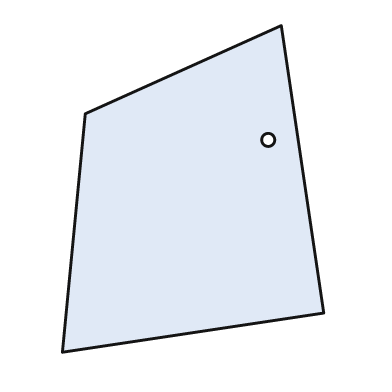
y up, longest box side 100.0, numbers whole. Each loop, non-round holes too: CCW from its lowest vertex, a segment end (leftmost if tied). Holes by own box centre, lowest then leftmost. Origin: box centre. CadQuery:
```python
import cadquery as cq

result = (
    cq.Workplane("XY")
    .moveTo(-40.0, -50.0)
    .lineTo(40.0, -38.0)
    .lineTo(27.0, 50.0)
    .lineTo(-33.0, 23.0)
    .close()
    .moveTo(23.0, 15.0)
    .circle(2.0)
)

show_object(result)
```